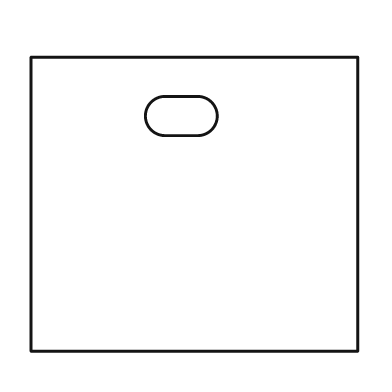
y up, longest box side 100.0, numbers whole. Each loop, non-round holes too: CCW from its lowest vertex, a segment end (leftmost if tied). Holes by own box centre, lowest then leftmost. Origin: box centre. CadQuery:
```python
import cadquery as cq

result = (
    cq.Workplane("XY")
    .moveTo(-50.0, -45.0)
    .lineTo(50.0, -45.0)
    .lineTo(50.0, 45.0)
    .lineTo(-50.0, 45.0)
    .close()
    .moveTo(-9.0, 21.0)
    .lineTo(1.0, 21.0)
    .threePointArc((7.0, 27.0), (1.0, 33.0))
    .lineTo(-9.0, 33.0)
    .threePointArc((-15.0, 27.0), (-9.0, 21.0))
    .close()
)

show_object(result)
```